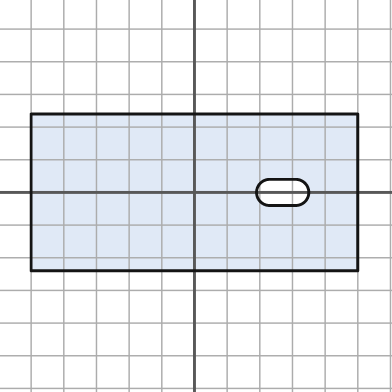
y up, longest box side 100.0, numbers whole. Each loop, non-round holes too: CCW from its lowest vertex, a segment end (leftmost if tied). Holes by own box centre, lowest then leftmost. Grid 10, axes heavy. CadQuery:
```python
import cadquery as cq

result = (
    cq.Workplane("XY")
    .moveTo(-50.0, -24.0)
    .lineTo(50.0, -24.0)
    .lineTo(50.0, 24.0)
    .lineTo(-50.0, 24.0)
    .close()
    .moveTo(23.0, -4.0)
    .lineTo(31.0, -4.0)
    .threePointArc((35.0, 0.0), (31.0, 4.0))
    .lineTo(23.0, 4.0)
    .threePointArc((19.0, 0.0), (23.0, -4.0))
    .close()
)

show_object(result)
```